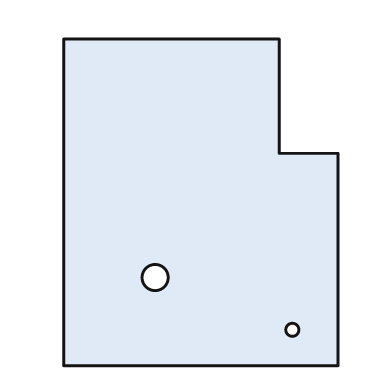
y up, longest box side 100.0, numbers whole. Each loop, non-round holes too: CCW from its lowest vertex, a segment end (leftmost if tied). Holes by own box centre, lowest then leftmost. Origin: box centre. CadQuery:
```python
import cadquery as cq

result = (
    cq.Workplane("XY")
    .moveTo(-42.0, -50.0)
    .lineTo(42.0, -50.0)
    .lineTo(42.0, 15.0)
    .lineTo(24.0, 15.0)
    .lineTo(24.0, 50.0)
    .lineTo(-42.0, 50.0)
    .close()
    .moveTo(28.0, -39.0)
    .circle(2.0)
    .moveTo(-14.0, -23.0)
    .circle(4.0)
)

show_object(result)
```